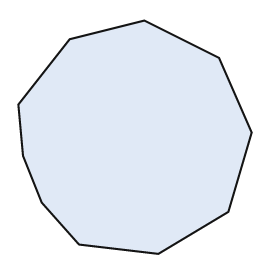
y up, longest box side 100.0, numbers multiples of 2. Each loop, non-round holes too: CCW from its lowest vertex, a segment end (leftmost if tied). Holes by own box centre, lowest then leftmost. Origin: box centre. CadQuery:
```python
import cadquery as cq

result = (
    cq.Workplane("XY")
    .moveTo(10.0, -50.0)
    .lineTo(40.0, -32.0)
    .lineTo(50.0, 2.0)
    .lineTo(36.0, 34.0)
    .lineTo(4.0, 50.0)
    .lineTo(-28.0, 42.0)
    .lineTo(-50.0, 14.0)
    .lineTo(-48.0, -8.0)
    .lineTo(-40.0, -28.0)
    .lineTo(-24.0, -46.0)
    .close()
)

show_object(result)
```